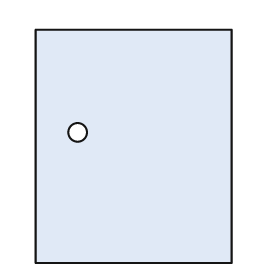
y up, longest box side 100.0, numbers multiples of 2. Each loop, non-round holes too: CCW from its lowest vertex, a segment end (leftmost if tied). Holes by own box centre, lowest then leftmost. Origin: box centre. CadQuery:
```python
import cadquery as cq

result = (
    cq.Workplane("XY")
    .moveTo(-42.0, -50.0)
    .lineTo(42.0, -50.0)
    .lineTo(42.0, 50.0)
    .lineTo(-42.0, 50.0)
    .close()
    .moveTo(-24.0, 6.0)
    .circle(4.0)
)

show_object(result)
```